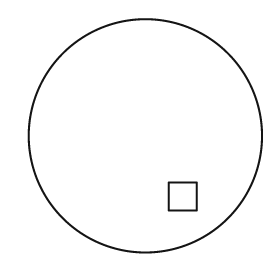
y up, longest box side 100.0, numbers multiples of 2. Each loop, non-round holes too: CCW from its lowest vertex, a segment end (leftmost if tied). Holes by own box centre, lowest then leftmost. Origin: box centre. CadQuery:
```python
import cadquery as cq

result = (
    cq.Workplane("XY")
    .moveTo(0.0, 0.0)
    .circle(50.0)
    .moveTo(10.0, -32.0)
    .lineTo(22.0, -32.0)
    .lineTo(22.0, -20.0)
    .lineTo(10.0, -20.0)
    .close()
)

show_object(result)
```